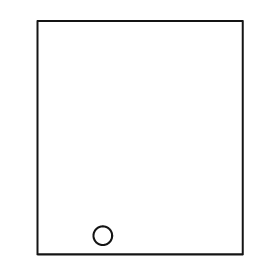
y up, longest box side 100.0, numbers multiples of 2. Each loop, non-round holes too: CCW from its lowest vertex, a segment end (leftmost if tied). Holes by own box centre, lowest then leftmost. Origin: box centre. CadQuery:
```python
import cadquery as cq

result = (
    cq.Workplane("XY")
    .moveTo(-44.0, -50.0)
    .lineTo(44.0, -50.0)
    .lineTo(44.0, 50.0)
    .lineTo(-44.0, 50.0)
    .close()
    .moveTo(-16.0, -42.0)
    .circle(4.0)
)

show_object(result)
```